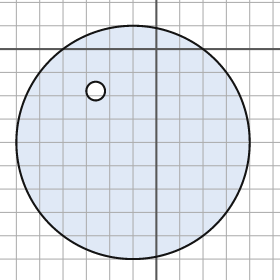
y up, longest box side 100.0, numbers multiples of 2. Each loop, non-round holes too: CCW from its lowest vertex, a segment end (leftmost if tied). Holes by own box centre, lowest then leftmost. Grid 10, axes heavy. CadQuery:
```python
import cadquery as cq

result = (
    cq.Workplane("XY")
    .moveTo(-10.0, -40.0)
    .circle(50.0)
    .moveTo(-26.0, -18.0)
    .circle(4.0)
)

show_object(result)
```